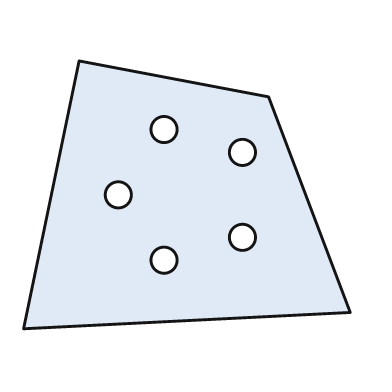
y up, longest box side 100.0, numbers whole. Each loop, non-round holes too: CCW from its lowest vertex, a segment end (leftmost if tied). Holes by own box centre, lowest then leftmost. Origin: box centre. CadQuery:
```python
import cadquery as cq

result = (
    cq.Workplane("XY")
    .moveTo(-50.0, -41.0)
    .lineTo(50.0, -36.0)
    .lineTo(25.0, 30.0)
    .lineTo(-33.0, 41.0)
    .close()
    .moveTo(-7.0, -20.0)
    .circle(4.0)
    .moveTo(17.0, -13.0)
    .circle(4.0)
    .moveTo(-21.0, 0.0)
    .circle(4.0)
    .moveTo(17.0, 13.0)
    .circle(4.0)
    .moveTo(-7.0, 20.0)
    .circle(4.0)
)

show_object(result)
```